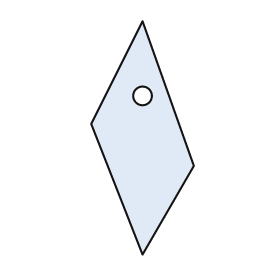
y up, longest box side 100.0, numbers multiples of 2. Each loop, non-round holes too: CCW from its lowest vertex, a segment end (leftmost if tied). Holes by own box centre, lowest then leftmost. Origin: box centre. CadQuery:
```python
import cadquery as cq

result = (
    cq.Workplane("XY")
    .moveTo(0.0, -50.0)
    .lineTo(22.0, -12.0)
    .lineTo(0.0, 50.0)
    .lineTo(-22.0, 6.0)
    .close()
    .moveTo(0.0, 18.0)
    .circle(4.0)
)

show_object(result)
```